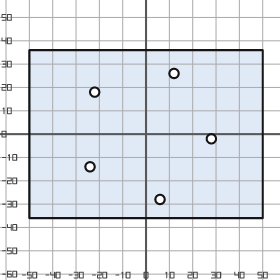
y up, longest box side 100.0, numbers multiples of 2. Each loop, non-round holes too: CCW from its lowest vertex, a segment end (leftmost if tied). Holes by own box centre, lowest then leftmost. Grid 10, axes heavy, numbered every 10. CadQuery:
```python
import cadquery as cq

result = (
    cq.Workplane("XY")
    .moveTo(-50.0, -36.0)
    .lineTo(50.0, -36.0)
    .lineTo(50.0, 36.0)
    .lineTo(-50.0, 36.0)
    .close()
    .moveTo(6.0, -28.0)
    .circle(2.0)
    .moveTo(-24.0, -14.0)
    .circle(2.0)
    .moveTo(28.0, -2.0)
    .circle(2.0)
    .moveTo(-22.0, 18.0)
    .circle(2.0)
    .moveTo(12.0, 26.0)
    .circle(2.0)
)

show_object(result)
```